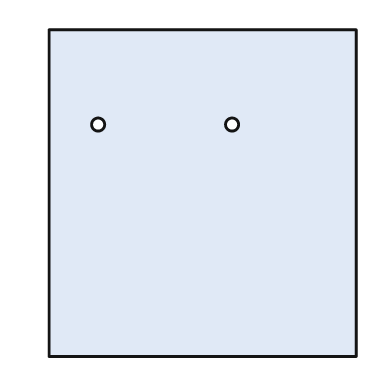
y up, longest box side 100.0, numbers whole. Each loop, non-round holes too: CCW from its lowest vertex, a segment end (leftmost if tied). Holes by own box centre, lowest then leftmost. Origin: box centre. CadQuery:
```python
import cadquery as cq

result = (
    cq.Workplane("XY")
    .moveTo(-47.0, -50.0)
    .lineTo(47.0, -50.0)
    .lineTo(47.0, 50.0)
    .lineTo(-47.0, 50.0)
    .close()
    .moveTo(-32.0, 21.0)
    .circle(2.0)
    .moveTo(9.0, 21.0)
    .circle(2.0)
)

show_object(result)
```